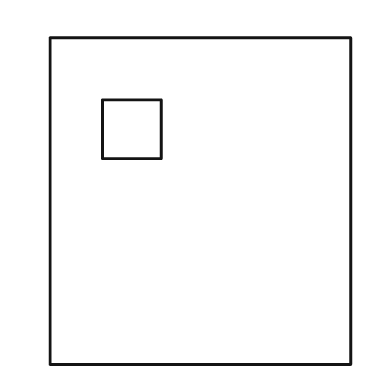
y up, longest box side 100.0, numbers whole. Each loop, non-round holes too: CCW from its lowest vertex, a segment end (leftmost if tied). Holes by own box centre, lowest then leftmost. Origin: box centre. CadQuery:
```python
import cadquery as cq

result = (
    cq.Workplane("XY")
    .moveTo(-46.0, -50.0)
    .lineTo(46.0, -50.0)
    .lineTo(46.0, 50.0)
    .lineTo(-46.0, 50.0)
    .close()
    .moveTo(-30.0, 13.0)
    .lineTo(-12.0, 13.0)
    .lineTo(-12.0, 31.0)
    .lineTo(-30.0, 31.0)
    .close()
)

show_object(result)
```